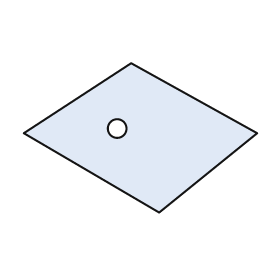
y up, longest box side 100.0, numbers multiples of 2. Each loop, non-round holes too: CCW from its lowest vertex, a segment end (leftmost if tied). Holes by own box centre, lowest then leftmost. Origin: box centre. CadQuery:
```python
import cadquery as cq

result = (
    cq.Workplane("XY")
    .moveTo(8.0, -32.0)
    .lineTo(50.0, 2.0)
    .lineTo(-4.0, 32.0)
    .lineTo(-50.0, 2.0)
    .close()
    .moveTo(-10.0, 4.0)
    .circle(4.0)
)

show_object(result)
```